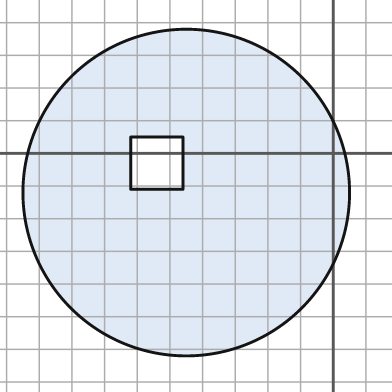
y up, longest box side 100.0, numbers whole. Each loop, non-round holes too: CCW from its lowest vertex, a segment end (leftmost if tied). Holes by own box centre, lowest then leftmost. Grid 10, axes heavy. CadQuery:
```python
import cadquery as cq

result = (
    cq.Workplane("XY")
    .moveTo(-45.0, -12.0)
    .circle(50.0)
    .moveTo(-62.0, -11.0)
    .lineTo(-46.0, -11.0)
    .lineTo(-46.0, 5.0)
    .lineTo(-62.0, 5.0)
    .close()
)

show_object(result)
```